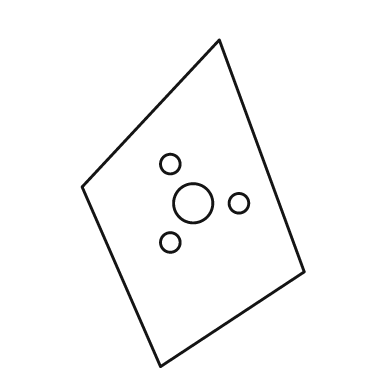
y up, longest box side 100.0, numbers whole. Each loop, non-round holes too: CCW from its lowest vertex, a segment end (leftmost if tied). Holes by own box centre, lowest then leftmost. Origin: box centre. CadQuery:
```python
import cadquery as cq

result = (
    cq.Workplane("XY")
    .moveTo(-10.0, -50.0)
    .lineTo(34.0, -21.0)
    .lineTo(8.0, 50.0)
    .lineTo(-34.0, 5.0)
    .close()
    .moveTo(-7.0, -12.0)
    .circle(3.0)
    .moveTo(0.0, 0.0)
    .circle(6.0)
    .moveTo(14.0, 0.0)
    .circle(3.0)
    .moveTo(-7.0, 12.0)
    .circle(3.0)
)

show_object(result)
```